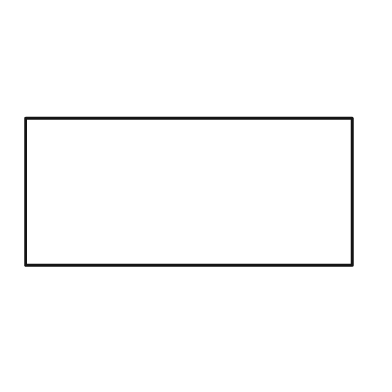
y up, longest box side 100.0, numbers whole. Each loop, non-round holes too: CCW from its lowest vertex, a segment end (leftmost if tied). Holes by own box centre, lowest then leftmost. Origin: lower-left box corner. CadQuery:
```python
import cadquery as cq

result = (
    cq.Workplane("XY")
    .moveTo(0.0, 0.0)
    .lineTo(100.0, 0.0)
    .lineTo(100.0, 45.0)
    .lineTo(0.0, 45.0)
    .close()
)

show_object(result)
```